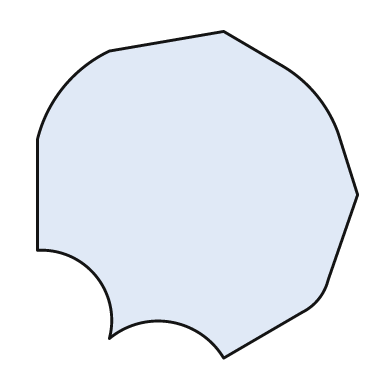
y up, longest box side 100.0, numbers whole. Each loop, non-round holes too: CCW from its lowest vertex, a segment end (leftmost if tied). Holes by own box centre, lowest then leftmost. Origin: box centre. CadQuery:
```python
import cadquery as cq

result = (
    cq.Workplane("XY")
    .moveTo(8.0, -50.0)
    .lineTo(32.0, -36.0)
    .threePointArc((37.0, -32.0), (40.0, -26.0))
    .lineTo(49.0, 0.0)
    .lineTo(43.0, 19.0)
    .threePointArc((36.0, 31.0), (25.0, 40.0))
    .lineTo(8.0, 50.0)
    .lineTo(-27.0, 44.0)
    .threePointArc((-41.0, 33.0), (-49.0, 17.0))
    .lineTo(-49.0, -17.0)
    .threePointArc((-31.0, -25.0), (-27.0, -44.0))
    .threePointArc((-8.0, -39.0), (8.0, -50.0))
    .close()
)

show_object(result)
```